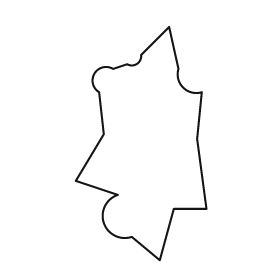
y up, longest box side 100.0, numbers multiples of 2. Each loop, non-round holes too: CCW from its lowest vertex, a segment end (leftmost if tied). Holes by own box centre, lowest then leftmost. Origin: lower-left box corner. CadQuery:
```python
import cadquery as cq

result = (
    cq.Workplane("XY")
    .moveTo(36.0, 0.0)
    .lineTo(42.0, 22.0)
    .lineTo(56.0, 22.0)
    .lineTo(52.0, 52.0)
    .lineTo(54.0, 72.0)
    .threePointArc((46.0, 74.0), (44.0, 82.0))
    .lineTo(40.0, 100.0)
    .lineTo(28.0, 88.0)
    .threePointArc((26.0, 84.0), (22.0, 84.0))
    .lineTo(16.0, 82.0)
    .threePointArc((8.0, 80.0), (10.0, 72.0))
    .lineTo(12.0, 54.0)
    .lineTo(0.0, 34.0)
    .lineTo(18.0, 28.0)
    .threePointArc((12.0, 16.0), (24.0, 10.0))
    .close()
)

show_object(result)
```